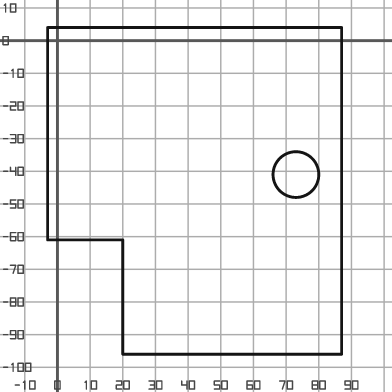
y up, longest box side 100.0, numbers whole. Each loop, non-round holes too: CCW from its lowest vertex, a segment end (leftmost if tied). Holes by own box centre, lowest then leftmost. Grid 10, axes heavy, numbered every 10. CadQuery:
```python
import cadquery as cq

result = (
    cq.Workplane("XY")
    .moveTo(20.0, -96.0)
    .lineTo(87.0, -96.0)
    .lineTo(87.0, 4.0)
    .lineTo(-3.0, 4.0)
    .lineTo(-3.0, -61.0)
    .lineTo(20.0, -61.0)
    .close()
    .moveTo(73.0, -41.0)
    .circle(7.0)
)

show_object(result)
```